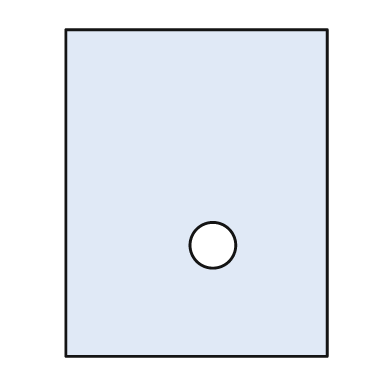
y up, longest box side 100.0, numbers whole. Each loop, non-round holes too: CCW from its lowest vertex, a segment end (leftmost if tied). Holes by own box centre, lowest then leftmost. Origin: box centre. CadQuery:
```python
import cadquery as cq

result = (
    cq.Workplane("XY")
    .moveTo(-40.0, -50.0)
    .lineTo(40.0, -50.0)
    .lineTo(40.0, 50.0)
    .lineTo(-40.0, 50.0)
    .close()
    .moveTo(5.0, -16.0)
    .circle(7.0)
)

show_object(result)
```